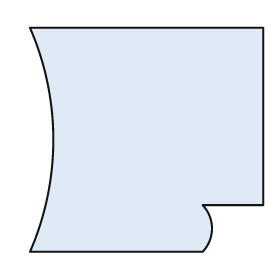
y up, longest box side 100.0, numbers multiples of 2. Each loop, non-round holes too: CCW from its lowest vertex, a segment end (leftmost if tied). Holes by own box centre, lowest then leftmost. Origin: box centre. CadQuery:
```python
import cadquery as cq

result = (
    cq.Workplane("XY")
    .moveTo(-50.0, -48.0)
    .lineTo(24.0, -48.0)
    .threePointArc((28.0, -38.0), (24.0, -28.0))
    .lineTo(50.0, -28.0)
    .lineTo(50.0, 48.0)
    .lineTo(-50.0, 48.0)
    .threePointArc((-40.0, 0.0), (-50.0, -48.0))
    .close()
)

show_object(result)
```